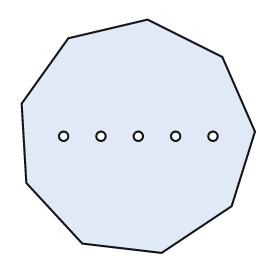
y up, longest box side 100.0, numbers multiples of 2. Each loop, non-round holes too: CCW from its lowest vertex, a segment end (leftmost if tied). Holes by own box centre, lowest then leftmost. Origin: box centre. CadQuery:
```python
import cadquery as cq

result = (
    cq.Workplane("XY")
    .moveTo(10.0, -50.0)
    .lineTo(40.0, -30.0)
    .lineTo(50.0, 2.0)
    .lineTo(36.0, 34.0)
    .lineTo(4.0, 50.0)
    .lineTo(-30.0, 42.0)
    .lineTo(-50.0, 14.0)
    .lineTo(-48.0, -20.0)
    .lineTo(-24.0, -46.0)
    .close()
    .moveTo(-32.0, 0.0)
    .circle(2.0)
    .moveTo(-16.0, 0.0)
    .circle(2.0)
    .moveTo(0.0, 0.0)
    .circle(2.0)
    .moveTo(16.0, 0.0)
    .circle(2.0)
    .moveTo(32.0, 0.0)
    .circle(2.0)
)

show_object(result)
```